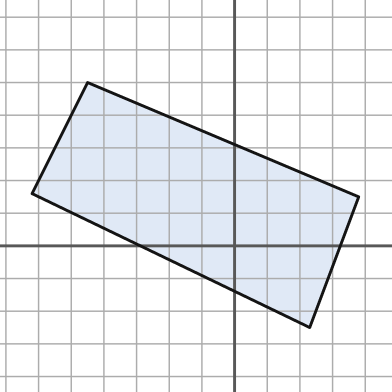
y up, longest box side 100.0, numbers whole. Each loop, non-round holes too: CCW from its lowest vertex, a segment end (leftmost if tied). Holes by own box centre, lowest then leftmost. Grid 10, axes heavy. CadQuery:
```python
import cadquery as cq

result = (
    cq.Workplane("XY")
    .moveTo(23.0, -25.0)
    .lineTo(38.0, 15.0)
    .lineTo(-45.0, 50.0)
    .lineTo(-62.0, 16.0)
    .close()
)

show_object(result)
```